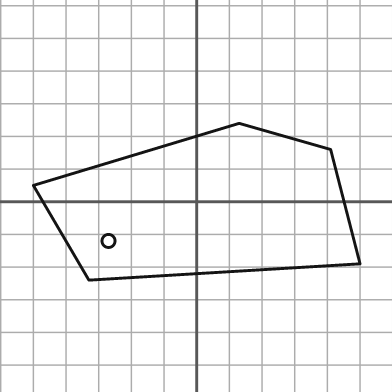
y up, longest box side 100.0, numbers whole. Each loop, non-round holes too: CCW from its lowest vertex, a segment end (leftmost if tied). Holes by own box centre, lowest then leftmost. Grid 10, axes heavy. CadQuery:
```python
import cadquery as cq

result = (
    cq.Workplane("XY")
    .moveTo(-33.0, -24.0)
    .lineTo(50.0, -19.0)
    .lineTo(41.0, 16.0)
    .lineTo(13.0, 24.0)
    .lineTo(-50.0, 5.0)
    .close()
    .moveTo(-27.0, -12.0)
    .circle(2.0)
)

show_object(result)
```